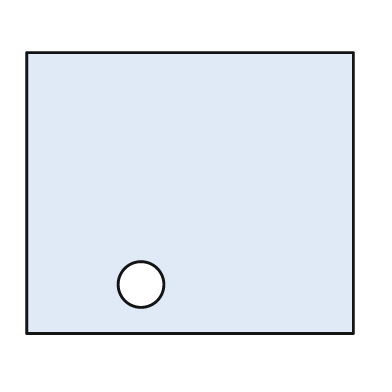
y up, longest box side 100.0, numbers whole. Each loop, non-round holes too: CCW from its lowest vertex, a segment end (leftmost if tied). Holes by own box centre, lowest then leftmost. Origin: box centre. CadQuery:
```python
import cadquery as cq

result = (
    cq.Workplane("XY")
    .moveTo(-50.0, -43.0)
    .lineTo(50.0, -43.0)
    .lineTo(50.0, 43.0)
    .lineTo(-50.0, 43.0)
    .close()
    .moveTo(-15.0, -28.0)
    .circle(7.0)
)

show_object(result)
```